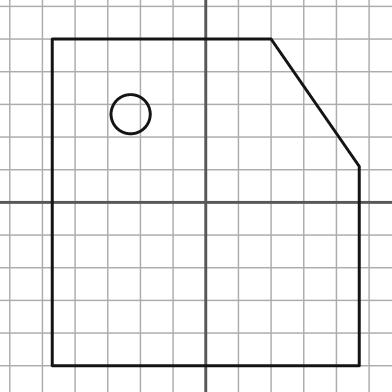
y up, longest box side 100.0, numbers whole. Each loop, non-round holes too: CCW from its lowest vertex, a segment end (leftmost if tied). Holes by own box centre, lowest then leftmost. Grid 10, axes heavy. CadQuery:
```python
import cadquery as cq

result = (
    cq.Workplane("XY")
    .moveTo(-47.0, -50.0)
    .lineTo(47.0, -50.0)
    .lineTo(47.0, 11.0)
    .lineTo(20.0, 50.0)
    .lineTo(-47.0, 50.0)
    .close()
    .moveTo(-23.0, 27.0)
    .circle(6.0)
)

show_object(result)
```